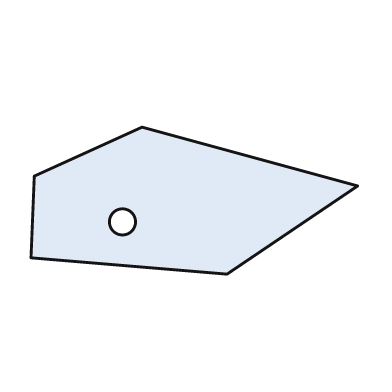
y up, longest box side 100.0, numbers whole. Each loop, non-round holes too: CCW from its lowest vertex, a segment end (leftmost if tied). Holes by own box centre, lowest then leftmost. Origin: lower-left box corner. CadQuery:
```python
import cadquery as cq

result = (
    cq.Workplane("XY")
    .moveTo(60.0, 0.0)
    .lineTo(100.0, 27.0)
    .lineTo(34.0, 45.0)
    .lineTo(1.0, 30.0)
    .lineTo(0.0, 5.0)
    .close()
    .moveTo(28.0, 16.0)
    .circle(4.0)
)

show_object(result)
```